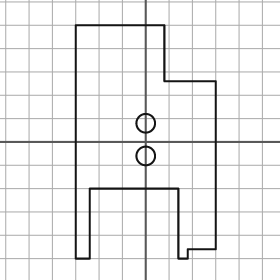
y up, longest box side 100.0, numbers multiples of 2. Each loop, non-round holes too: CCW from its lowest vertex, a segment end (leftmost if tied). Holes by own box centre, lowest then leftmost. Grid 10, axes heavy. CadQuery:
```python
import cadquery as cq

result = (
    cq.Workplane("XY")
    .moveTo(-30.0, -50.0)
    .lineTo(-24.0, -50.0)
    .lineTo(-24.0, -20.0)
    .lineTo(14.0, -20.0)
    .lineTo(14.0, -50.0)
    .lineTo(18.0, -50.0)
    .lineTo(18.0, -46.0)
    .lineTo(30.0, -46.0)
    .lineTo(30.0, 26.0)
    .lineTo(8.0, 26.0)
    .lineTo(8.0, 50.0)
    .lineTo(-30.0, 50.0)
    .close()
    .moveTo(0.0, -6.0)
    .circle(4.0)
    .moveTo(0.0, 8.0)
    .circle(4.0)
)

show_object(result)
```